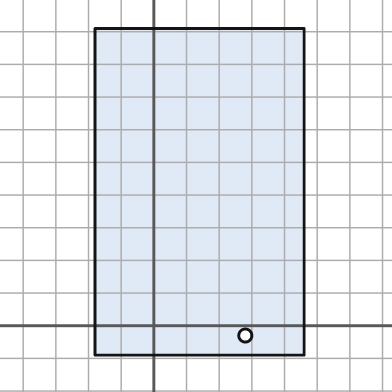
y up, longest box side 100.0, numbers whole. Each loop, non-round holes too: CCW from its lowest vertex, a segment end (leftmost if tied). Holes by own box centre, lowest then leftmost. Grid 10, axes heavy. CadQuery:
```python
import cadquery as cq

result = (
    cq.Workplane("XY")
    .moveTo(-18.0, -9.0)
    .lineTo(46.0, -9.0)
    .lineTo(46.0, 91.0)
    .lineTo(-18.0, 91.0)
    .close()
    .moveTo(28.0, -3.0)
    .circle(2.0)
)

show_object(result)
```